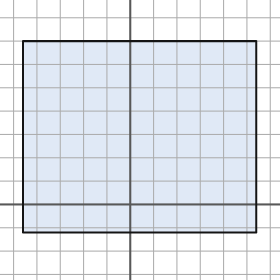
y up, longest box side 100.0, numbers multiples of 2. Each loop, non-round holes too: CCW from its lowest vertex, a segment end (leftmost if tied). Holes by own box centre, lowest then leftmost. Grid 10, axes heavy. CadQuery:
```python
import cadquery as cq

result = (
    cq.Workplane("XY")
    .moveTo(-46.0, -12.0)
    .lineTo(54.0, -12.0)
    .lineTo(54.0, 70.0)
    .lineTo(-46.0, 70.0)
    .close()
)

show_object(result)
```